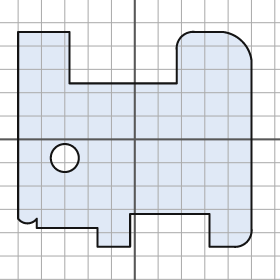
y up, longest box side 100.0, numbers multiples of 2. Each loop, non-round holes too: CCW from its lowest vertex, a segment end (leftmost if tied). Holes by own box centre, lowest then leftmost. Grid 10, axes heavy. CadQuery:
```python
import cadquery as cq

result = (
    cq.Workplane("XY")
    .moveTo(-16.0, -46.0)
    .lineTo(-2.0, -46.0)
    .lineTo(-2.0, -32.0)
    .lineTo(32.0, -32.0)
    .lineTo(32.0, -46.0)
    .lineTo(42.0, -46.0)
    .threePointArc((48.0, -44.0), (50.0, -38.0))
    .lineTo(50.0, 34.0)
    .threePointArc((46.0, 42.0), (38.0, 46.0))
    .lineTo(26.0, 46.0)
    .threePointArc((20.0, 44.0), (18.0, 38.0))
    .lineTo(18.0, 24.0)
    .lineTo(-28.0, 24.0)
    .lineTo(-28.0, 46.0)
    .lineTo(-50.0, 46.0)
    .lineTo(-50.0, -34.0)
    .threePointArc((-46.0, -36.0), (-42.0, -34.0))
    .lineTo(-42.0, -38.0)
    .lineTo(-16.0, -38.0)
    .close()
    .moveTo(-30.0, -8.0)
    .circle(6.0)
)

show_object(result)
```